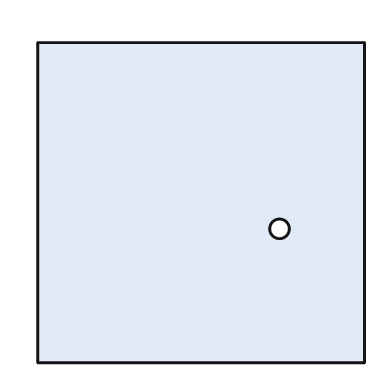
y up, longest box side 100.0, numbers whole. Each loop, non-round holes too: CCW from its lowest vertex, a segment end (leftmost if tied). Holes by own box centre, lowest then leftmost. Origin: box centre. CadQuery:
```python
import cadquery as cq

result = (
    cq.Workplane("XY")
    .moveTo(-50.0, -49.0)
    .lineTo(50.0, -49.0)
    .lineTo(50.0, 49.0)
    .lineTo(-50.0, 49.0)
    .close()
    .moveTo(24.0, -8.0)
    .circle(3.0)
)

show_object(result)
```